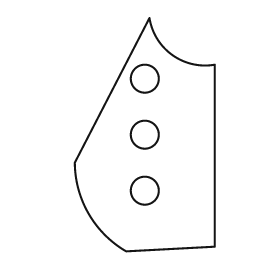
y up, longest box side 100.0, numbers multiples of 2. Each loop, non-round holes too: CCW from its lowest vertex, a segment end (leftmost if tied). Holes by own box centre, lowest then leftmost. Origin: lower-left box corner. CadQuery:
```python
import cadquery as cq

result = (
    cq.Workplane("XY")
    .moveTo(22.0, 0.0)
    .lineTo(60.0, 2.0)
    .lineTo(60.0, 80.0)
    .threePointArc((42.0, 84.0), (32.0, 100.0))
    .lineTo(0.0, 38.0)
    .threePointArc((6.0, 16.0), (22.0, 0.0))
    .close()
    .moveTo(30.0, 26.0)
    .circle(6.0)
    .moveTo(30.0, 50.0)
    .circle(6.0)
    .moveTo(30.0, 74.0)
    .circle(6.0)
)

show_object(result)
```